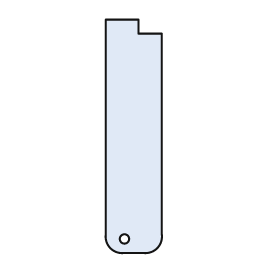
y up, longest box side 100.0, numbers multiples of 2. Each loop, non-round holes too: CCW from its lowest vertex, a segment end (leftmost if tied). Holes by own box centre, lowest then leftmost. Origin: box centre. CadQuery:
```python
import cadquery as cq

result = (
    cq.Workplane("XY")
    .moveTo(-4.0, -50.0)
    .lineTo(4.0, -50.0)
    .threePointArc((10.0, -48.0), (12.0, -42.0))
    .lineTo(12.0, 44.0)
    .lineTo(2.0, 44.0)
    .lineTo(2.0, 50.0)
    .lineTo(-12.0, 50.0)
    .lineTo(-12.0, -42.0)
    .threePointArc((-10.0, -48.0), (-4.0, -50.0))
    .close()
    .moveTo(-4.0, -44.0)
    .circle(2.0)
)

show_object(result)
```